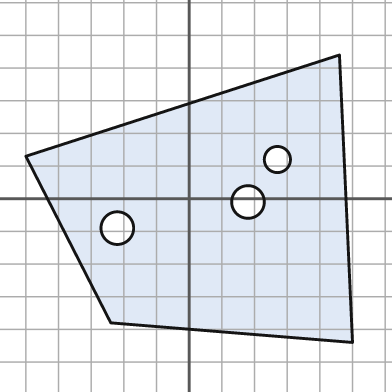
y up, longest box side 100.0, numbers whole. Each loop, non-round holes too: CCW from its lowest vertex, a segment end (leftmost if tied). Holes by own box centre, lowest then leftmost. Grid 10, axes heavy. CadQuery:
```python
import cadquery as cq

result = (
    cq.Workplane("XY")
    .moveTo(50.0, -44.0)
    .lineTo(46.0, 44.0)
    .lineTo(-50.0, 13.0)
    .lineTo(-24.0, -38.0)
    .close()
    .moveTo(-22.0, -9.0)
    .circle(5.0)
    .moveTo(18.0, -1.0)
    .circle(5.0)
    .moveTo(27.0, 12.0)
    .circle(4.0)
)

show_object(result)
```